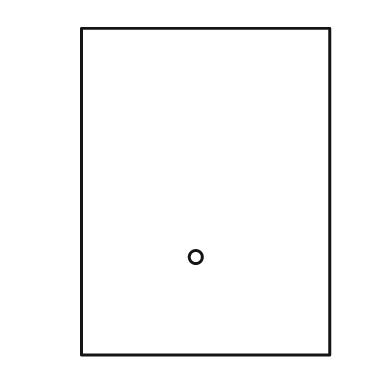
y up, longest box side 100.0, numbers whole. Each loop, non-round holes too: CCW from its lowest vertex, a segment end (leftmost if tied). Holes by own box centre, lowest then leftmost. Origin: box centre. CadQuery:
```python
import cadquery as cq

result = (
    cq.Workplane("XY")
    .moveTo(-38.0, -50.0)
    .lineTo(38.0, -50.0)
    .lineTo(38.0, 50.0)
    .lineTo(-38.0, 50.0)
    .close()
    .moveTo(-3.0, -20.0)
    .circle(2.0)
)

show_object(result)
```